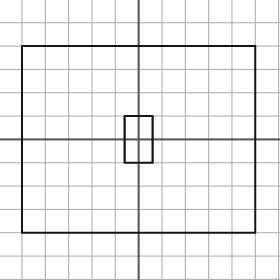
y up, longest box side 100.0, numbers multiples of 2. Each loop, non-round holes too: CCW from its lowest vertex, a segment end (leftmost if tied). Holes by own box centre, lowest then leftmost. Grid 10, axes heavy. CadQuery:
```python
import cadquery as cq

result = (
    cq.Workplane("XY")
    .moveTo(-50.0, -40.0)
    .lineTo(50.0, -40.0)
    .lineTo(50.0, 40.0)
    .lineTo(-50.0, 40.0)
    .close()
    .moveTo(-6.0, -10.0)
    .lineTo(6.0, -10.0)
    .lineTo(6.0, 10.0)
    .lineTo(-6.0, 10.0)
    .close()
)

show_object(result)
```